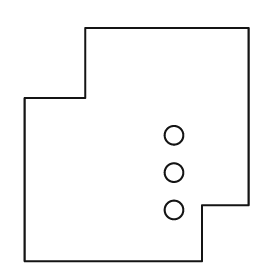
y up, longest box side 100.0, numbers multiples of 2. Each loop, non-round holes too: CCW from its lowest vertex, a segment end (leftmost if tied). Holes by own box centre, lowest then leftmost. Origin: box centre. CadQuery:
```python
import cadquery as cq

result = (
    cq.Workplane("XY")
    .moveTo(-48.0, -50.0)
    .lineTo(28.0, -50.0)
    .lineTo(28.0, -26.0)
    .lineTo(48.0, -26.0)
    .lineTo(48.0, 50.0)
    .lineTo(-22.0, 50.0)
    .lineTo(-22.0, 20.0)
    .lineTo(-48.0, 20.0)
    .close()
    .moveTo(16.0, -28.0)
    .circle(4.0)
    .moveTo(16.0, -12.0)
    .circle(4.0)
    .moveTo(16.0, 4.0)
    .circle(4.0)
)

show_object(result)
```